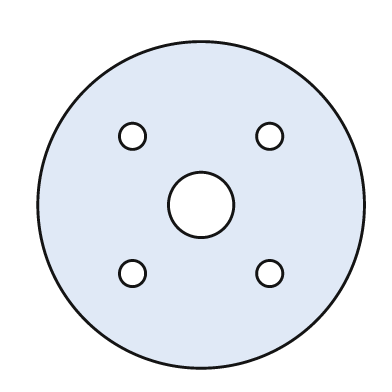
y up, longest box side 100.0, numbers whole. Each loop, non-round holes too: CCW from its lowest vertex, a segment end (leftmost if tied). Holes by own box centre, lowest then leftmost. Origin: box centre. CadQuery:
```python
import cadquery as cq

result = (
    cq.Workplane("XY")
    .moveTo(0.0, 0.0)
    .circle(50.0)
    .moveTo(-21.0, -21.0)
    .circle(4.0)
    .moveTo(21.0, -21.0)
    .circle(4.0)
    .moveTo(0.0, 0.0)
    .circle(10.0)
    .moveTo(-21.0, 21.0)
    .circle(4.0)
    .moveTo(21.0, 21.0)
    .circle(4.0)
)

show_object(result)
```